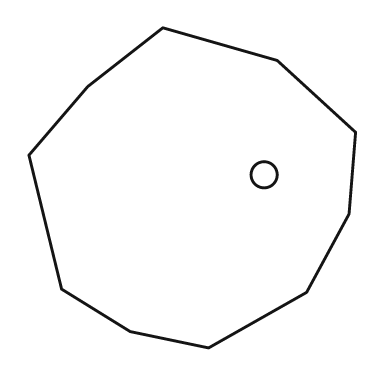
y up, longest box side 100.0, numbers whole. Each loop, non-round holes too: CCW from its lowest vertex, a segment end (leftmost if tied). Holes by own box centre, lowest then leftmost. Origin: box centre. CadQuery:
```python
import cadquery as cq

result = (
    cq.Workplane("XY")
    .moveTo(5.0, -49.0)
    .lineTo(35.0, -32.0)
    .lineTo(48.0, -8.0)
    .lineTo(50.0, 17.0)
    .lineTo(26.0, 39.0)
    .lineTo(-9.0, 49.0)
    .lineTo(-32.0, 31.0)
    .lineTo(-50.0, 10.0)
    .lineTo(-40.0, -31.0)
    .lineTo(-19.0, -44.0)
    .close()
    .moveTo(22.0, 4.0)
    .circle(4.0)
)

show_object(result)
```